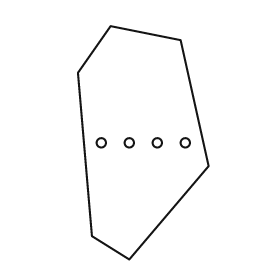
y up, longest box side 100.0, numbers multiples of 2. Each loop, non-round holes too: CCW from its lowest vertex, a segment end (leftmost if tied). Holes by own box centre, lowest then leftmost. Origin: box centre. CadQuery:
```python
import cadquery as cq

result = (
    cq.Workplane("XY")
    .moveTo(-6.0, -50.0)
    .lineTo(28.0, -10.0)
    .lineTo(16.0, 44.0)
    .lineTo(-14.0, 50.0)
    .lineTo(-28.0, 30.0)
    .lineTo(-22.0, -40.0)
    .close()
    .moveTo(-18.0, 0.0)
    .circle(2.0)
    .moveTo(-6.0, 0.0)
    .circle(2.0)
    .moveTo(6.0, 0.0)
    .circle(2.0)
    .moveTo(18.0, 0.0)
    .circle(2.0)
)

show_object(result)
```